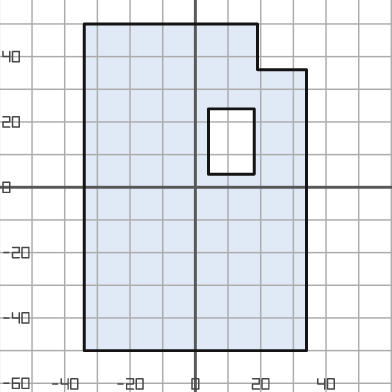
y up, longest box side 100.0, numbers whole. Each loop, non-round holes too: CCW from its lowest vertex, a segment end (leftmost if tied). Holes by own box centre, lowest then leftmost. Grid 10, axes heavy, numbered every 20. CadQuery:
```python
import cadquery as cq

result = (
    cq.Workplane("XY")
    .moveTo(-34.0, -50.0)
    .lineTo(34.0, -50.0)
    .lineTo(34.0, 36.0)
    .lineTo(19.0, 36.0)
    .lineTo(19.0, 50.0)
    .lineTo(-34.0, 50.0)
    .close()
    .moveTo(4.0, 4.0)
    .lineTo(18.0, 4.0)
    .lineTo(18.0, 24.0)
    .lineTo(4.0, 24.0)
    .close()
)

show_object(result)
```